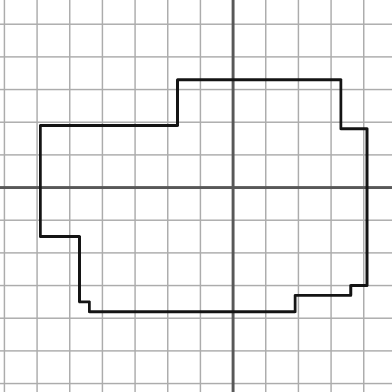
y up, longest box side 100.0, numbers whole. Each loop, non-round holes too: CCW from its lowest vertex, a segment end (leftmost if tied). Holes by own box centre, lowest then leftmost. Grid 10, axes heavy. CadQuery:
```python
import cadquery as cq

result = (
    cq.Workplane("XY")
    .moveTo(-44.0, -38.0)
    .lineTo(19.0, -38.0)
    .lineTo(19.0, -33.0)
    .lineTo(36.0, -33.0)
    .lineTo(36.0, -30.0)
    .lineTo(41.0, -30.0)
    .lineTo(41.0, 18.0)
    .lineTo(33.0, 18.0)
    .lineTo(33.0, 33.0)
    .lineTo(-17.0, 33.0)
    .lineTo(-17.0, 19.0)
    .lineTo(-59.0, 19.0)
    .lineTo(-59.0, -15.0)
    .lineTo(-47.0, -15.0)
    .lineTo(-47.0, -35.0)
    .lineTo(-44.0, -35.0)
    .close()
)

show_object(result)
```